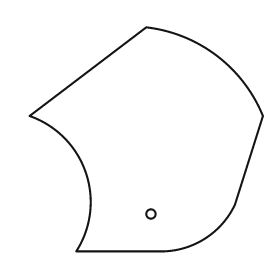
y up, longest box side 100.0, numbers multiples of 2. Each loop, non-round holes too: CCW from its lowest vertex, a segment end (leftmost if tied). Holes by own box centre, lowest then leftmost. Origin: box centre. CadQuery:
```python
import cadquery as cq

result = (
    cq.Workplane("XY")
    .moveTo(-30.0, -48.0)
    .lineTo(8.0, -48.0)
    .threePointArc((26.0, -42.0), (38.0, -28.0))
    .lineTo(50.0, 10.0)
    .threePointArc((30.0, 36.0), (0.0, 48.0))
    .lineTo(-50.0, 10.0)
    .threePointArc((-26.0, -14.0), (-30.0, -48.0))
    .close()
    .moveTo(2.0, -32.0)
    .circle(2.0)
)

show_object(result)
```